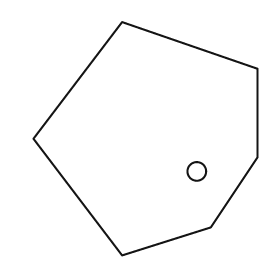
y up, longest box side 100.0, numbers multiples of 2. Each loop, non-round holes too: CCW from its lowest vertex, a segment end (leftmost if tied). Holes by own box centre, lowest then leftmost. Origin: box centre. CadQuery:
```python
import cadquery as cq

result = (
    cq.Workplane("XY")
    .moveTo(-10.0, -50.0)
    .lineTo(28.0, -38.0)
    .lineTo(48.0, -8.0)
    .lineTo(48.0, 30.0)
    .lineTo(-10.0, 50.0)
    .lineTo(-48.0, 0.0)
    .close()
    .moveTo(22.0, -14.0)
    .circle(4.0)
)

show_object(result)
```